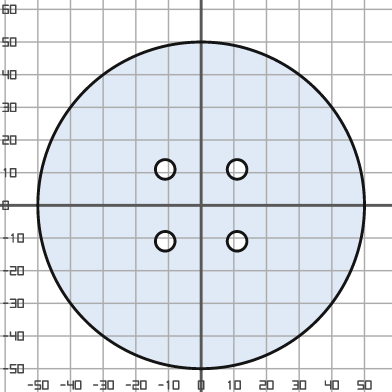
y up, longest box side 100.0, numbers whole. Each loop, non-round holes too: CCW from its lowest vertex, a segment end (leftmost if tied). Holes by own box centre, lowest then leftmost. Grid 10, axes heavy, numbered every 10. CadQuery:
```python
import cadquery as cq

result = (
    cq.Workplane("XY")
    .moveTo(0.0, 0.0)
    .circle(50.0)
    .moveTo(-11.0, -11.0)
    .circle(3.0)
    .moveTo(11.0, -11.0)
    .circle(3.0)
    .moveTo(-11.0, 11.0)
    .circle(3.0)
    .moveTo(11.0, 11.0)
    .circle(3.0)
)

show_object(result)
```